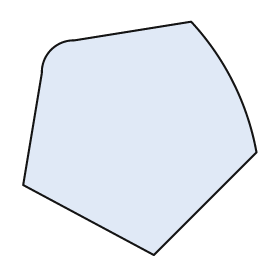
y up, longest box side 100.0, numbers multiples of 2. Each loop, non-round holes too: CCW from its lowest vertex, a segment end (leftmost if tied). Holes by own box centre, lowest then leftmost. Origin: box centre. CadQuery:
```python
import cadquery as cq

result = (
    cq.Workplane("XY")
    .moveTo(6.0, -50.0)
    .lineTo(50.0, -6.0)
    .threePointArc((40.0, 24.0), (22.0, 50.0))
    .lineTo(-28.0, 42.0)
    .threePointArc((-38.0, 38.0), (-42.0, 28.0))
    .lineTo(-50.0, -20.0)
    .close()
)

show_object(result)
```